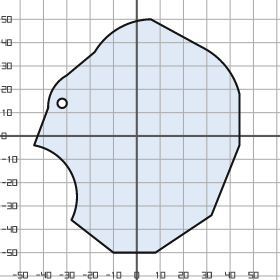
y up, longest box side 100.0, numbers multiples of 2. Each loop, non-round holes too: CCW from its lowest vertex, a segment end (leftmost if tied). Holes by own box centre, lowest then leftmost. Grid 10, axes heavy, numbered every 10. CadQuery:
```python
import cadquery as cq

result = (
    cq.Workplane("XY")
    .moveTo(-10.0, -50.0)
    .lineTo(8.0, -50.0)
    .lineTo(32.0, -34.0)
    .lineTo(44.0, -4.0)
    .lineTo(44.0, 18.0)
    .threePointArc((38.0, 30.0), (28.0, 38.0))
    .lineTo(6.0, 50.0)
    .threePointArc((-8.0, 46.0), (-18.0, 36.0))
    .lineTo(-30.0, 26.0)
    .threePointArc((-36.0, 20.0), (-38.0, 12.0))
    .lineTo(-44.0, -4.0)
    .threePointArc((-28.0, -16.0), (-28.0, -36.0))
    .close()
    .moveTo(-32.0, 14.0)
    .circle(2.0)
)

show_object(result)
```